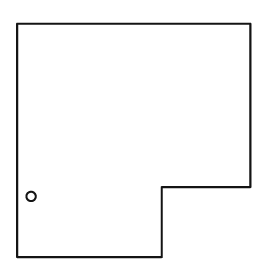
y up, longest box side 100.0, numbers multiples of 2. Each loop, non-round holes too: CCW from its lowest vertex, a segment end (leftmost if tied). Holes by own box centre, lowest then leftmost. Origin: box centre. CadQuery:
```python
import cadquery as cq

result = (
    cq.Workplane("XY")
    .moveTo(-50.0, -50.0)
    .lineTo(12.0, -50.0)
    .lineTo(12.0, -20.0)
    .lineTo(50.0, -20.0)
    .lineTo(50.0, 50.0)
    .lineTo(-50.0, 50.0)
    .close()
    .moveTo(-44.0, -24.0)
    .circle(2.0)
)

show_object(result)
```